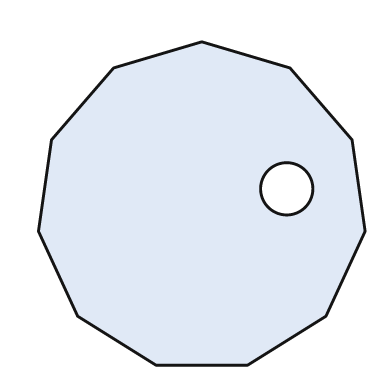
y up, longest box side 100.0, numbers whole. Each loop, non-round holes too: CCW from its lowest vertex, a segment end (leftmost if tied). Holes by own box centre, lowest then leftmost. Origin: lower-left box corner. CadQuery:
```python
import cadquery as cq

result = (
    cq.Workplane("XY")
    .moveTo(36.0, 0.0)
    .lineTo(64.0, 0.0)
    .lineTo(88.0, 15.0)
    .lineTo(100.0, 41.0)
    .lineTo(96.0, 69.0)
    .lineTo(77.0, 91.0)
    .lineTo(50.0, 99.0)
    .lineTo(23.0, 91.0)
    .lineTo(4.0, 69.0)
    .lineTo(0.0, 41.0)
    .lineTo(12.0, 15.0)
    .close()
    .moveTo(76.0, 54.0)
    .circle(8.0)
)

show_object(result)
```